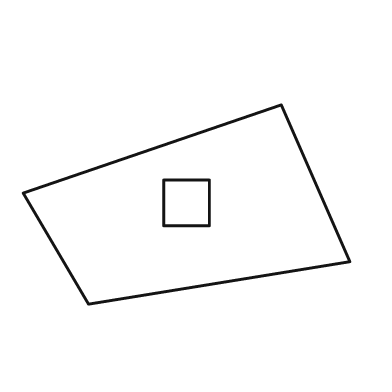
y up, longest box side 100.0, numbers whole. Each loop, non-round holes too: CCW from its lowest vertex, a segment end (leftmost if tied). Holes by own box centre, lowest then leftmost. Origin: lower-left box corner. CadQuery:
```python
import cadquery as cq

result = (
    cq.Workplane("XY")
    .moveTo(20.0, 0.0)
    .lineTo(100.0, 13.0)
    .lineTo(79.0, 61.0)
    .lineTo(0.0, 34.0)
    .close()
    .moveTo(43.0, 24.0)
    .lineTo(57.0, 24.0)
    .lineTo(57.0, 38.0)
    .lineTo(43.0, 38.0)
    .close()
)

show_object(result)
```